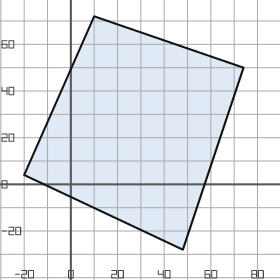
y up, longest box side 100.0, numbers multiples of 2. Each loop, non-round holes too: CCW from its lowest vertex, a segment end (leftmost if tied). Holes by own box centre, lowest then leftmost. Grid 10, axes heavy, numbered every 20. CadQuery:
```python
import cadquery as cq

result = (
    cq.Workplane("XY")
    .moveTo(48.0, -28.0)
    .lineTo(74.0, 50.0)
    .lineTo(10.0, 72.0)
    .lineTo(-20.0, 4.0)
    .close()
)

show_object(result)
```